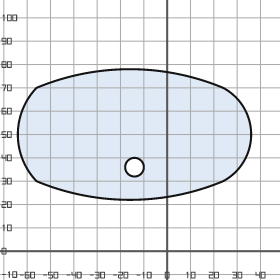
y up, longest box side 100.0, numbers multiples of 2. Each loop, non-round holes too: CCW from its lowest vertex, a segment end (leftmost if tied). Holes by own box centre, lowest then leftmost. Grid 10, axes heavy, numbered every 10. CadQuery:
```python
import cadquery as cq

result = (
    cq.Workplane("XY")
    .moveTo(-56.0, 30.0)
    .threePointArc((-16.0, 22.0), (24.0, 30.0))
    .threePointArc((36.0, 50.0), (24.0, 70.0))
    .threePointArc((-16.0, 78.0), (-56.0, 70.0))
    .threePointArc((-64.0, 50.0), (-56.0, 30.0))
    .close()
    .moveTo(-14.0, 36.0)
    .circle(4.0)
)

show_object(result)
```